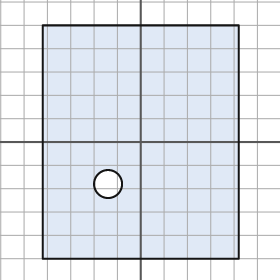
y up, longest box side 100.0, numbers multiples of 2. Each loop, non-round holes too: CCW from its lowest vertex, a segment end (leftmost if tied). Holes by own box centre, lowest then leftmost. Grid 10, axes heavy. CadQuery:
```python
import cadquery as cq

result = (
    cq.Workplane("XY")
    .moveTo(-42.0, -50.0)
    .lineTo(42.0, -50.0)
    .lineTo(42.0, 50.0)
    .lineTo(-42.0, 50.0)
    .close()
    .moveTo(-14.0, -18.0)
    .circle(6.0)
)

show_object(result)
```